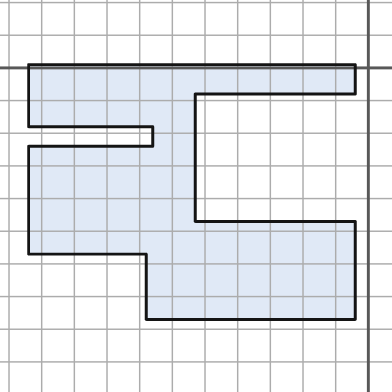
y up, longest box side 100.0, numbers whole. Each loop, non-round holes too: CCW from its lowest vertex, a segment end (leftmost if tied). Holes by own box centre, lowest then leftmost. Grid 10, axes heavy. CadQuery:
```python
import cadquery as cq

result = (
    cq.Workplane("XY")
    .moveTo(-68.0, -77.0)
    .lineTo(-4.0, -77.0)
    .lineTo(-4.0, -47.0)
    .lineTo(-53.0, -47.0)
    .lineTo(-53.0, -8.0)
    .lineTo(-4.0, -8.0)
    .lineTo(-4.0, 1.0)
    .lineTo(-104.0, 1.0)
    .lineTo(-104.0, -18.0)
    .lineTo(-66.0, -18.0)
    .lineTo(-66.0, -24.0)
    .lineTo(-104.0, -24.0)
    .lineTo(-104.0, -57.0)
    .lineTo(-68.0, -57.0)
    .close()
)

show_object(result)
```